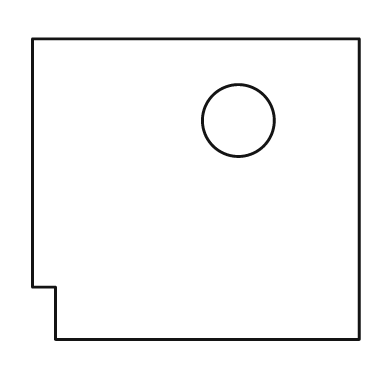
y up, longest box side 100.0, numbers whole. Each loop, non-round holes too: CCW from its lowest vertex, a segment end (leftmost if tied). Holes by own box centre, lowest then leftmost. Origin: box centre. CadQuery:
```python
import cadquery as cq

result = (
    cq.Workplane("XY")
    .moveTo(-43.0, -46.0)
    .lineTo(50.0, -46.0)
    .lineTo(50.0, 46.0)
    .lineTo(-50.0, 46.0)
    .lineTo(-50.0, -30.0)
    .lineTo(-43.0, -30.0)
    .close()
    .moveTo(13.0, 21.0)
    .circle(11.0)
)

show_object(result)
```